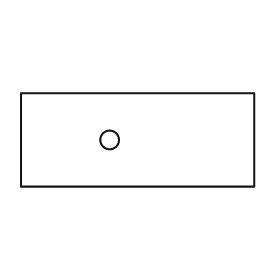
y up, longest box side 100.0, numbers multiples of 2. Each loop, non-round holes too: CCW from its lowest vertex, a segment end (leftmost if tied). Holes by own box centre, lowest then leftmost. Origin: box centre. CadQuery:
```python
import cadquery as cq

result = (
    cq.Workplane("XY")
    .moveTo(-50.0, -20.0)
    .lineTo(50.0, -20.0)
    .lineTo(50.0, 20.0)
    .lineTo(-50.0, 20.0)
    .close()
    .moveTo(-12.0, 0.0)
    .circle(4.0)
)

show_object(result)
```